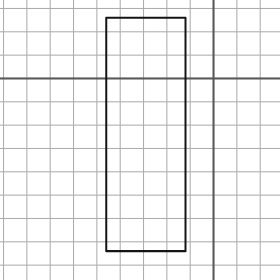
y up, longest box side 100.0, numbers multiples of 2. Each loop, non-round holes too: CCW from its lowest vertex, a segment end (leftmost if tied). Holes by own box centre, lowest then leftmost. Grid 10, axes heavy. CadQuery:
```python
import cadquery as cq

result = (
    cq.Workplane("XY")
    .moveTo(-46.0, -74.0)
    .lineTo(-12.0, -74.0)
    .lineTo(-12.0, 26.0)
    .lineTo(-46.0, 26.0)
    .close()
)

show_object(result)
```